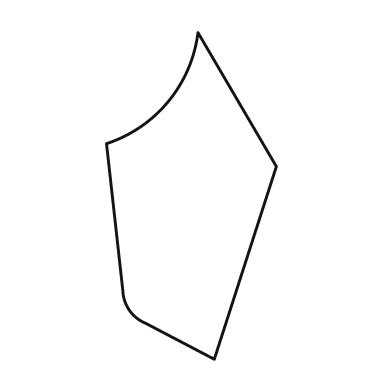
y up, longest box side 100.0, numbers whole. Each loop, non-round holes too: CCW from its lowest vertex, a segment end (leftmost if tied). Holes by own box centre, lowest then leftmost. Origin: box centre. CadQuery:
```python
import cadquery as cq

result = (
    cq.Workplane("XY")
    .moveTo(7.0, -50.0)
    .lineTo(26.0, 9.0)
    .lineTo(2.0, 50.0)
    .threePointArc((-7.0, 29.0), (-26.0, 16.0))
    .lineTo(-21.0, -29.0)
    .threePointArc((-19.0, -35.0), (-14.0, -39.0))
    .close()
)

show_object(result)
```